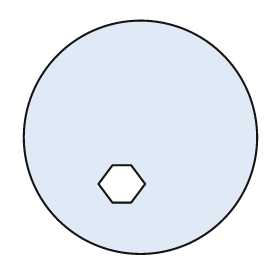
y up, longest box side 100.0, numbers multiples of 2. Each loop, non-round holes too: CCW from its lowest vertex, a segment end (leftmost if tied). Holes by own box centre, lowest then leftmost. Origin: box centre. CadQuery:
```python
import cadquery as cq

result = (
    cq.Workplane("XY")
    .moveTo(0.0, 0.0)
    .circle(50.0)
    .moveTo(-12.0, -28.0)
    .lineTo(-4.0, -28.0)
    .lineTo(2.0, -20.0)
    .lineTo(-4.0, -12.0)
    .lineTo(-12.0, -12.0)
    .lineTo(-18.0, -20.0)
    .close()
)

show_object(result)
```